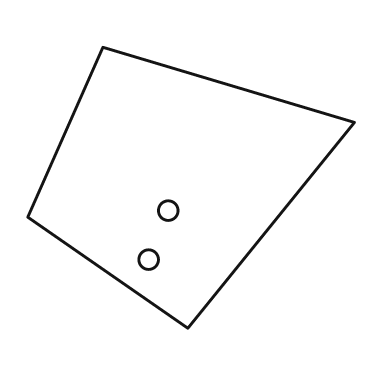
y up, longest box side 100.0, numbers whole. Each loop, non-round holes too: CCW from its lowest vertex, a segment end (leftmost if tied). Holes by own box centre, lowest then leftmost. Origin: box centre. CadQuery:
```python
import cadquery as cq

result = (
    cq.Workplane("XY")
    .moveTo(-1.0, -43.0)
    .lineTo(50.0, 20.0)
    .lineTo(-27.0, 43.0)
    .lineTo(-50.0, -9.0)
    .close()
    .moveTo(-13.0, -22.0)
    .circle(3.0)
    .moveTo(-7.0, -7.0)
    .circle(3.0)
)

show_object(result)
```